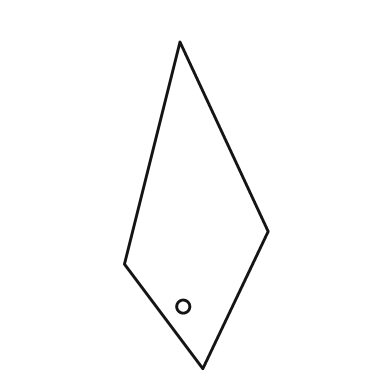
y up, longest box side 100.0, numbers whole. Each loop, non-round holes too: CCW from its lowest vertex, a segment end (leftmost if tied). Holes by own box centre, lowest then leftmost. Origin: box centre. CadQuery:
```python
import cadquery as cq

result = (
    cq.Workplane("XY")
    .moveTo(2.0, -50.0)
    .lineTo(22.0, -8.0)
    .lineTo(-5.0, 50.0)
    .lineTo(-22.0, -18.0)
    .close()
    .moveTo(-4.0, -31.0)
    .circle(2.0)
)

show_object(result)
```